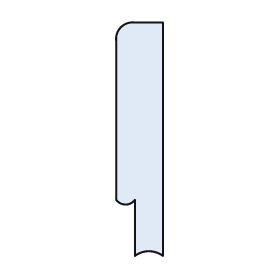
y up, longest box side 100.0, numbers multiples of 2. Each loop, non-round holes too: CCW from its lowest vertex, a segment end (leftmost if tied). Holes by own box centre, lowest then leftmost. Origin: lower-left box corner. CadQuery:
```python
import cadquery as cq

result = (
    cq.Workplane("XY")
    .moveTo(8.0, 0.0)
    .threePointArc((14.0, 2.0), (20.0, 0.0))
    .lineTo(20.0, 100.0)
    .lineTo(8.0, 100.0)
    .threePointArc((2.0, 98.0), (0.0, 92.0))
    .lineTo(0.0, 24.0)
    .threePointArc((4.0, 22.0), (8.0, 24.0))
    .close()
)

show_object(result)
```